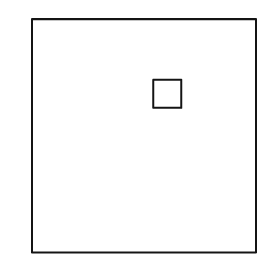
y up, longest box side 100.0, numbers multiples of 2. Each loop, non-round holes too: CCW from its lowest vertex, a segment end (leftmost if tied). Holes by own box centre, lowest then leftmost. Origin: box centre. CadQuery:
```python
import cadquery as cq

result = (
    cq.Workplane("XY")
    .moveTo(-48.0, -50.0)
    .lineTo(48.0, -50.0)
    .lineTo(48.0, 50.0)
    .lineTo(-48.0, 50.0)
    .close()
    .moveTo(4.0, 12.0)
    .lineTo(16.0, 12.0)
    .lineTo(16.0, 24.0)
    .lineTo(4.0, 24.0)
    .close()
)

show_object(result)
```